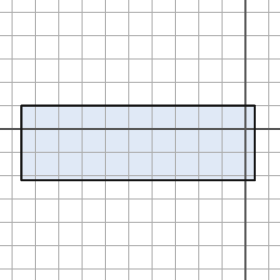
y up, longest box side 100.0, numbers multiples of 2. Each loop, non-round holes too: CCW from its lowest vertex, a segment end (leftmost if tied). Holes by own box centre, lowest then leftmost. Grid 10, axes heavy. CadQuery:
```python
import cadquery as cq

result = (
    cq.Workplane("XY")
    .moveTo(-96.0, -22.0)
    .lineTo(4.0, -22.0)
    .lineTo(4.0, 10.0)
    .lineTo(-96.0, 10.0)
    .close()
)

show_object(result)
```